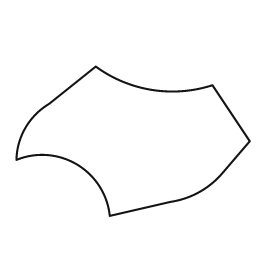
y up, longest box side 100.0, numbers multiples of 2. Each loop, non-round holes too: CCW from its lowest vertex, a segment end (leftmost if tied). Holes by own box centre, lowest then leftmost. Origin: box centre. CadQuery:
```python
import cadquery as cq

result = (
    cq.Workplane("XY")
    .moveTo(-10.0, -32.0)
    .lineTo(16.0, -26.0)
    .threePointArc((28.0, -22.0), (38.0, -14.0))
    .lineTo(50.0, 0.0)
    .lineTo(34.0, 24.0)
    .threePointArc((8.0, 22.0), (-16.0, 32.0))
    .lineTo(-36.0, 16.0)
    .threePointArc((-46.0, 6.0), (-50.0, -8.0))
    .threePointArc((-24.0, -10.0), (-10.0, -32.0))
    .close()
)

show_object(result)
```